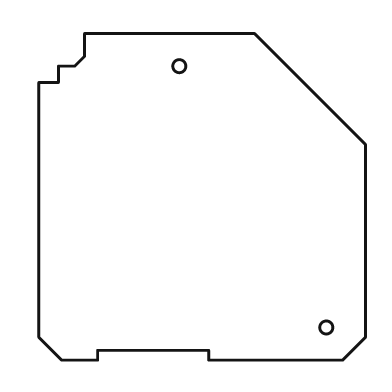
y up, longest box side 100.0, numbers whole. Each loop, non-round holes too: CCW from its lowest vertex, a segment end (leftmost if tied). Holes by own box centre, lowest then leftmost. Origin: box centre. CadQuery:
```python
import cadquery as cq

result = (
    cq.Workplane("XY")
    .moveTo(-43.0, -50.0)
    .lineTo(-32.0, -50.0)
    .lineTo(-32.0, -47.0)
    .lineTo(2.0, -47.0)
    .lineTo(2.0, -50.0)
    .lineTo(43.0, -50.0)
    .lineTo(50.0, -43.0)
    .lineTo(50.0, 16.0)
    .lineTo(16.0, 50.0)
    .lineTo(-36.0, 50.0)
    .lineTo(-36.0, 43.0)
    .lineTo(-39.0, 40.0)
    .lineTo(-44.0, 40.0)
    .lineTo(-44.0, 35.0)
    .lineTo(-50.0, 35.0)
    .lineTo(-50.0, -43.0)
    .close()
    .moveTo(38.0, -40.0)
    .circle(2.0)
    .moveTo(-7.0, 40.0)
    .circle(2.0)
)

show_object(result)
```